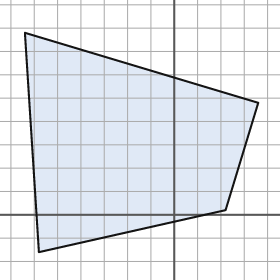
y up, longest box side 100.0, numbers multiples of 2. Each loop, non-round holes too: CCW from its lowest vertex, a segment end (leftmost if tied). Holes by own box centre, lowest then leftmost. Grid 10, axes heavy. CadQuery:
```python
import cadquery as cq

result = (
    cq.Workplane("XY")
    .moveTo(-58.0, -16.0)
    .lineTo(22.0, 2.0)
    .lineTo(36.0, 48.0)
    .lineTo(-64.0, 78.0)
    .close()
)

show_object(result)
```